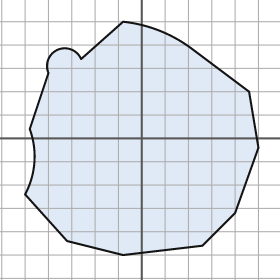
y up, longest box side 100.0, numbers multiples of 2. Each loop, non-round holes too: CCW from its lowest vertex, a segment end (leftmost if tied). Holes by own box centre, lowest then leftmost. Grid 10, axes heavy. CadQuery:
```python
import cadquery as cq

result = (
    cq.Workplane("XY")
    .moveTo(-8.0, -50.0)
    .lineTo(26.0, -46.0)
    .lineTo(40.0, -32.0)
    .lineTo(50.0, -4.0)
    .lineTo(46.0, 20.0)
    .lineTo(22.0, 38.0)
    .threePointArc((8.0, 46.0), (-8.0, 50.0))
    .lineTo(-26.0, 34.0)
    .threePointArc((-36.0, 38.0), (-40.0, 28.0))
    .lineTo(-48.0, 4.0)
    .threePointArc((-46.0, -10.0), (-50.0, -24.0))
    .lineTo(-32.0, -44.0)
    .close()
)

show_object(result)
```